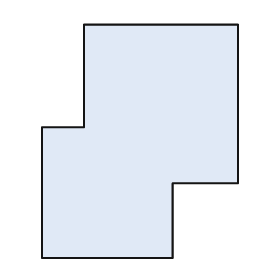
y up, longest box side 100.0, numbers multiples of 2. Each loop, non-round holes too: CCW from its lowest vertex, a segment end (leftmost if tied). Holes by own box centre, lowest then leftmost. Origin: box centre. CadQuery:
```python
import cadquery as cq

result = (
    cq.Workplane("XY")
    .moveTo(-42.0, -50.0)
    .lineTo(14.0, -50.0)
    .lineTo(14.0, -18.0)
    .lineTo(42.0, -18.0)
    .lineTo(42.0, 50.0)
    .lineTo(-24.0, 50.0)
    .lineTo(-24.0, 6.0)
    .lineTo(-42.0, 6.0)
    .close()
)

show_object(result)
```